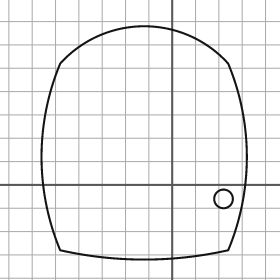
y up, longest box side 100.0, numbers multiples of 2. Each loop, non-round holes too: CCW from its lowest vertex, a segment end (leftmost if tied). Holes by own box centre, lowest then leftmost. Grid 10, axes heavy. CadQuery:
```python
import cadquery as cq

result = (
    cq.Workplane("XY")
    .moveTo(-48.0, -28.0)
    .threePointArc((-12.0, -32.0), (24.0, -28.0))
    .threePointArc((32.0, 12.0), (24.0, 52.0))
    .threePointArc((-12.0, 68.0), (-48.0, 52.0))
    .threePointArc((-56.0, 12.0), (-48.0, -28.0))
    .close()
    .moveTo(22.0, -6.0)
    .circle(4.0)
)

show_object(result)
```